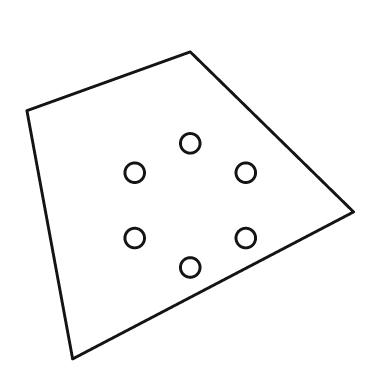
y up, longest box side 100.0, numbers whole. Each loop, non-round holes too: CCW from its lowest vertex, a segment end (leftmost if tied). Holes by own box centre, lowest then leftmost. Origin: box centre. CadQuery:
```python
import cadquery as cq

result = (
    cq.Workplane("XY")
    .moveTo(-36.0, -47.0)
    .lineTo(50.0, -2.0)
    .lineTo(0.0, 47.0)
    .lineTo(-50.0, 29.0)
    .close()
    .moveTo(0.0, -19.0)
    .circle(3.0)
    .moveTo(-17.0, -10.0)
    .circle(3.0)
    .moveTo(17.0, -10.0)
    .circle(3.0)
    .moveTo(-17.0, 10.0)
    .circle(3.0)
    .moveTo(17.0, 10.0)
    .circle(3.0)
    .moveTo(0.0, 19.0)
    .circle(3.0)
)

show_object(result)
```